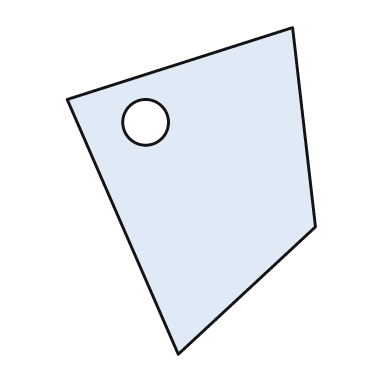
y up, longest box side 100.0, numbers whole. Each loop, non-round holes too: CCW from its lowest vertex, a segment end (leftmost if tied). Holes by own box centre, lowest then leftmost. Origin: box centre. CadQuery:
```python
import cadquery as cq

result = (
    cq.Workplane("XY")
    .moveTo(-4.0, -50.0)
    .lineTo(38.0, -11.0)
    .lineTo(31.0, 50.0)
    .lineTo(-38.0, 28.0)
    .close()
    .moveTo(-14.0, 21.0)
    .circle(7.0)
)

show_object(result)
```